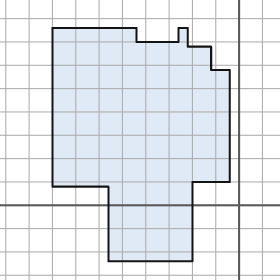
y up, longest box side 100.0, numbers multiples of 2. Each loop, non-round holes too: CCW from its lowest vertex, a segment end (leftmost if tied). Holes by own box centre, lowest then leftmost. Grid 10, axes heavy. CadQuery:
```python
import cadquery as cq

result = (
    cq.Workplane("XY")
    .moveTo(-56.0, -24.0)
    .lineTo(-20.0, -24.0)
    .lineTo(-20.0, 10.0)
    .lineTo(-4.0, 10.0)
    .lineTo(-4.0, 58.0)
    .lineTo(-12.0, 58.0)
    .lineTo(-12.0, 68.0)
    .lineTo(-22.0, 68.0)
    .lineTo(-22.0, 76.0)
    .lineTo(-26.0, 76.0)
    .lineTo(-26.0, 70.0)
    .lineTo(-44.0, 70.0)
    .lineTo(-44.0, 76.0)
    .lineTo(-80.0, 76.0)
    .lineTo(-80.0, 8.0)
    .lineTo(-56.0, 8.0)
    .close()
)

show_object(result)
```